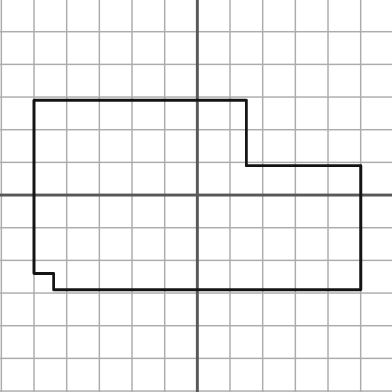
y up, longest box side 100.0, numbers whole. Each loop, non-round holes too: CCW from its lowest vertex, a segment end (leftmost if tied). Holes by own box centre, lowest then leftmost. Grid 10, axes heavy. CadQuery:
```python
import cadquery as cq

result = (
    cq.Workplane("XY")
    .moveTo(-44.0, -29.0)
    .lineTo(50.0, -29.0)
    .lineTo(50.0, 9.0)
    .lineTo(15.0, 9.0)
    .lineTo(15.0, 29.0)
    .lineTo(-50.0, 29.0)
    .lineTo(-50.0, -24.0)
    .lineTo(-44.0, -24.0)
    .close()
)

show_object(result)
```